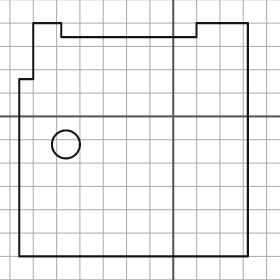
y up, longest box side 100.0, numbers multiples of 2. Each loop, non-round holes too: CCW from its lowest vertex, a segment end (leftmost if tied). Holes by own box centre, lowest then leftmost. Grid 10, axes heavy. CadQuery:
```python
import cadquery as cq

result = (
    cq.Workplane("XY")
    .moveTo(-66.0, -60.0)
    .lineTo(32.0, -60.0)
    .lineTo(32.0, 40.0)
    .lineTo(10.0, 40.0)
    .lineTo(10.0, 34.0)
    .lineTo(-48.0, 34.0)
    .lineTo(-48.0, 40.0)
    .lineTo(-60.0, 40.0)
    .lineTo(-60.0, 16.0)
    .lineTo(-66.0, 16.0)
    .close()
    .moveTo(-46.0, -12.0)
    .circle(6.0)
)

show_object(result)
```